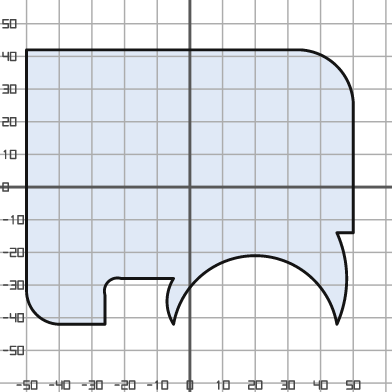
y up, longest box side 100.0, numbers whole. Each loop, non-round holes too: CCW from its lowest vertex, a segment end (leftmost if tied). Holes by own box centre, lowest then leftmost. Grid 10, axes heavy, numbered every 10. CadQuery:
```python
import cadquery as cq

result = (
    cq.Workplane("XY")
    .moveTo(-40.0, -42.0)
    .lineTo(-26.0, -42.0)
    .lineTo(-26.0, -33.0)
    .threePointArc((-25.0, -29.0), (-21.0, -28.0))
    .lineTo(-5.0, -28.0)
    .threePointArc((-7.0, -35.0), (-5.0, -42.0))
    .threePointArc((20.0, -21.0), (45.0, -42.0))
    .threePointArc((48.0, -28.0), (45.0, -14.0))
    .lineTo(50.0, -14.0)
    .lineTo(50.0, 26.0)
    .threePointArc((45.0, 37.0), (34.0, 42.0))
    .lineTo(-50.0, 42.0)
    .lineTo(-50.0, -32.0)
    .threePointArc((-47.0, -39.0), (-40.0, -42.0))
    .close()
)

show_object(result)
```